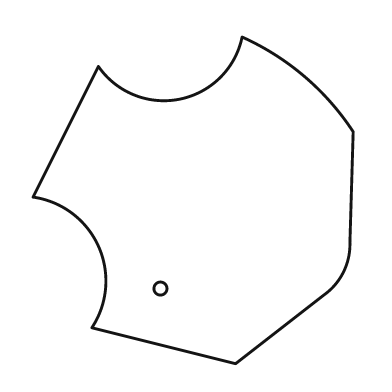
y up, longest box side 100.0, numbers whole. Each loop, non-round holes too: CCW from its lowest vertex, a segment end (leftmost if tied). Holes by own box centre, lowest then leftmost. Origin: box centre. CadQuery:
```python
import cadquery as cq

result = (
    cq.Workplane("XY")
    .moveTo(13.0, -50.0)
    .lineTo(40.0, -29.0)
    .threePointArc((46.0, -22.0), (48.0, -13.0))
    .lineTo(49.0, 21.0)
    .threePointArc((34.0, 38.0), (15.0, 50.0))
    .threePointArc((-4.0, 31.0), (-29.0, 41.0))
    .lineTo(-49.0, 1.0)
    .threePointArc((-29.0, -14.0), (-31.0, -39.0))
    .close()
    .moveTo(-10.0, -27.0)
    .circle(2.0)
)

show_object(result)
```